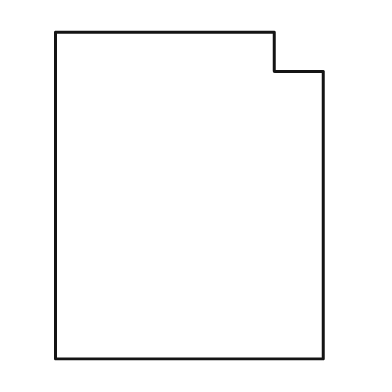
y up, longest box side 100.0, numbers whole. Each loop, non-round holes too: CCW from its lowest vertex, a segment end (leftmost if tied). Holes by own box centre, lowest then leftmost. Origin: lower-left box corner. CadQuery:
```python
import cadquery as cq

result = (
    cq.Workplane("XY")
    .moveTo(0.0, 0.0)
    .lineTo(82.0, 0.0)
    .lineTo(82.0, 88.0)
    .lineTo(67.0, 88.0)
    .lineTo(67.0, 100.0)
    .lineTo(0.0, 100.0)
    .close()
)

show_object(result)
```